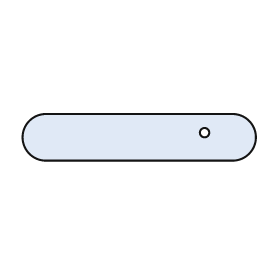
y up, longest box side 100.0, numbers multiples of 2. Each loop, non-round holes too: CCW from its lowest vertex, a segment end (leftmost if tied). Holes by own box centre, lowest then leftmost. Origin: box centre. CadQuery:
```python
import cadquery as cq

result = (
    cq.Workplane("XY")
    .moveTo(-40.0, -10.0)
    .lineTo(40.0, -10.0)
    .threePointArc((50.0, 0.0), (40.0, 10.0))
    .lineTo(-40.0, 10.0)
    .threePointArc((-50.0, 0.0), (-40.0, -10.0))
    .close()
    .moveTo(28.0, 2.0)
    .circle(2.0)
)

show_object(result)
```